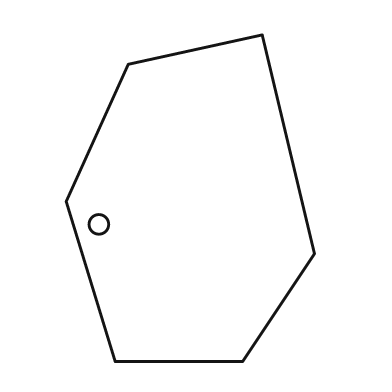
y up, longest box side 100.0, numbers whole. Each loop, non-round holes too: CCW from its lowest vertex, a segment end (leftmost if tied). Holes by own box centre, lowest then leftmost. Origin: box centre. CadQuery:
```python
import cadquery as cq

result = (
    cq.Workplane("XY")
    .moveTo(-23.0, -50.0)
    .lineTo(16.0, -50.0)
    .lineTo(38.0, -17.0)
    .lineTo(22.0, 50.0)
    .lineTo(-19.0, 41.0)
    .lineTo(-38.0, -1.0)
    .close()
    .moveTo(-28.0, -8.0)
    .circle(3.0)
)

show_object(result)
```